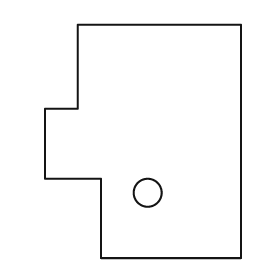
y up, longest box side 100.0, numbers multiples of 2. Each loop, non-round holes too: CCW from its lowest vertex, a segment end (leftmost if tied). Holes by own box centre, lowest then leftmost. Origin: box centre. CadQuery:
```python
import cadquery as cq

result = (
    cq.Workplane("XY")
    .moveTo(-18.0, -50.0)
    .lineTo(42.0, -50.0)
    .lineTo(42.0, 50.0)
    .lineTo(-28.0, 50.0)
    .lineTo(-28.0, 14.0)
    .lineTo(-42.0, 14.0)
    .lineTo(-42.0, -16.0)
    .lineTo(-18.0, -16.0)
    .close()
    .moveTo(2.0, -22.0)
    .circle(6.0)
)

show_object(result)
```